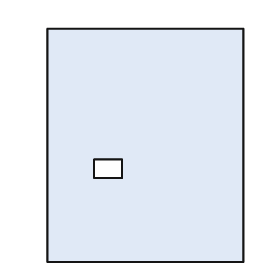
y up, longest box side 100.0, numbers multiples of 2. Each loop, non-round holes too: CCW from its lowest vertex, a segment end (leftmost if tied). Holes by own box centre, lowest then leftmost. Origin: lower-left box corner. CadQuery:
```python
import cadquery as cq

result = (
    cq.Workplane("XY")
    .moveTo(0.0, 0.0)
    .lineTo(84.0, 0.0)
    .lineTo(84.0, 100.0)
    .lineTo(0.0, 100.0)
    .close()
    .moveTo(20.0, 36.0)
    .lineTo(32.0, 36.0)
    .lineTo(32.0, 44.0)
    .lineTo(20.0, 44.0)
    .close()
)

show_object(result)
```